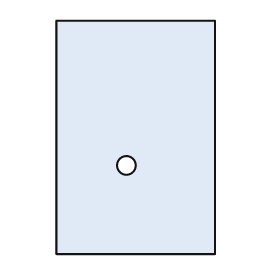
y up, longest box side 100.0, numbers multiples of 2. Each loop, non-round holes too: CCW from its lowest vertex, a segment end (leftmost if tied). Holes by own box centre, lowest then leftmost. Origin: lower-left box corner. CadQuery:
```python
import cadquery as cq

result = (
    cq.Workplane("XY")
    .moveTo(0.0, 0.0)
    .lineTo(68.0, 0.0)
    .lineTo(68.0, 100.0)
    .lineTo(0.0, 100.0)
    .close()
    .moveTo(30.0, 38.0)
    .circle(4.0)
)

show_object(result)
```